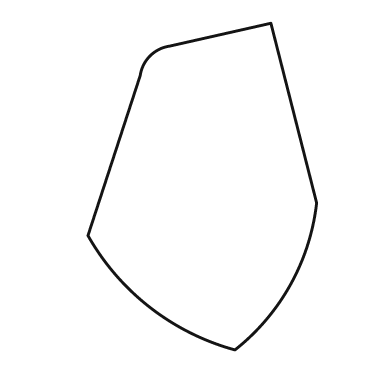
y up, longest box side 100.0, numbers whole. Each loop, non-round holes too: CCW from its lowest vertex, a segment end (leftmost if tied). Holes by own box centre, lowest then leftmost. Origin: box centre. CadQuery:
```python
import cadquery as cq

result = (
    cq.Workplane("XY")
    .moveTo(10.0, -50.0)
    .threePointArc((27.0, -30.0), (35.0, -5.0))
    .lineTo(21.0, 50.0)
    .lineTo(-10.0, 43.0)
    .threePointArc((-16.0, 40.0), (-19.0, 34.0))
    .lineTo(-35.0, -15.0)
    .threePointArc((-16.0, -37.0), (10.0, -50.0))
    .close()
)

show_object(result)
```